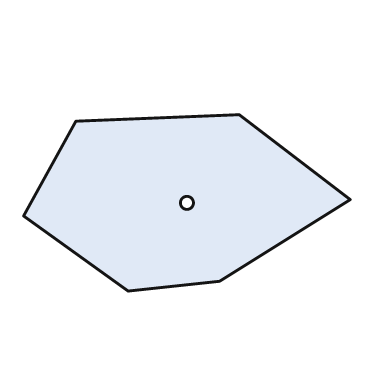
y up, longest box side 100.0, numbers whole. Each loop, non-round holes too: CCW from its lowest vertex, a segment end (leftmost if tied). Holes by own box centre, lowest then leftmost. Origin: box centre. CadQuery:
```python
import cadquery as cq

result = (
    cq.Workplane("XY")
    .moveTo(-18.0, -27.0)
    .lineTo(10.0, -24.0)
    .lineTo(50.0, 1.0)
    .lineTo(16.0, 27.0)
    .lineTo(-34.0, 25.0)
    .lineTo(-50.0, -4.0)
    .close()
    .moveTo(0.0, 0.0)
    .circle(2.0)
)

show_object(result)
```